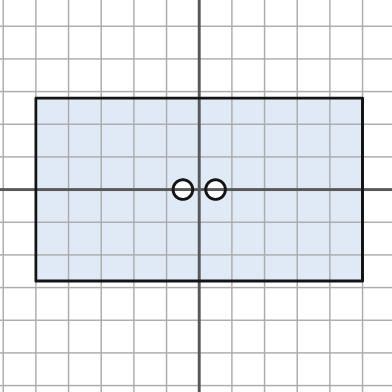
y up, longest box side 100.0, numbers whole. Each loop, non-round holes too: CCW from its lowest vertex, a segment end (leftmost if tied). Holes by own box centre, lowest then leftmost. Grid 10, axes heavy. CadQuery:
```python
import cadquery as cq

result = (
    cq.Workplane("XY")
    .moveTo(-50.0, -28.0)
    .lineTo(50.0, -28.0)
    .lineTo(50.0, 28.0)
    .lineTo(-50.0, 28.0)
    .close()
    .moveTo(-5.0, 0.0)
    .circle(3.0)
    .moveTo(5.0, 0.0)
    .circle(3.0)
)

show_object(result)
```